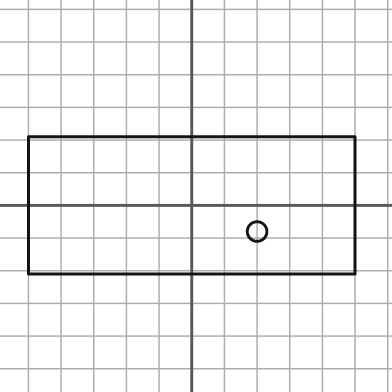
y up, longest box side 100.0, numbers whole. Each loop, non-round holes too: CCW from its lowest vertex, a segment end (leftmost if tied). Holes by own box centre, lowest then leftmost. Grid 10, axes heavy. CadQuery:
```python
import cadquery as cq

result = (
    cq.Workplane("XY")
    .moveTo(-50.0, -21.0)
    .lineTo(50.0, -21.0)
    .lineTo(50.0, 21.0)
    .lineTo(-50.0, 21.0)
    .close()
    .moveTo(20.0, -8.0)
    .circle(3.0)
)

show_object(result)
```